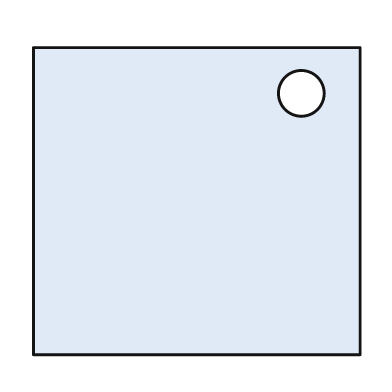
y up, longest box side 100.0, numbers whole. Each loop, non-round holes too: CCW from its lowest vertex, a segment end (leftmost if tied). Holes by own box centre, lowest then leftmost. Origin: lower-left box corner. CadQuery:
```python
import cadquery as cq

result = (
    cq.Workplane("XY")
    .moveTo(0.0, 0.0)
    .lineTo(100.0, 0.0)
    .lineTo(100.0, 94.0)
    .lineTo(0.0, 94.0)
    .close()
    .moveTo(82.0, 80.0)
    .circle(7.0)
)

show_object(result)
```